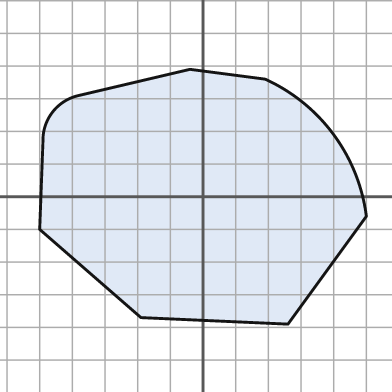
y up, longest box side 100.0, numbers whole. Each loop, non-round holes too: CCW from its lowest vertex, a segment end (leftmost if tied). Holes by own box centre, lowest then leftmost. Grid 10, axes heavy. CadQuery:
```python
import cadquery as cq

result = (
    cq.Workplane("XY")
    .moveTo(26.0, -39.0)
    .lineTo(50.0, -6.0)
    .threePointArc((40.0, 19.0), (19.0, 36.0))
    .lineTo(-4.0, 39.0)
    .lineTo(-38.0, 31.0)
    .threePointArc((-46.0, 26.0), (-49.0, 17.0))
    .lineTo(-50.0, -10.0)
    .lineTo(-19.0, -37.0)
    .close()
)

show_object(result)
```